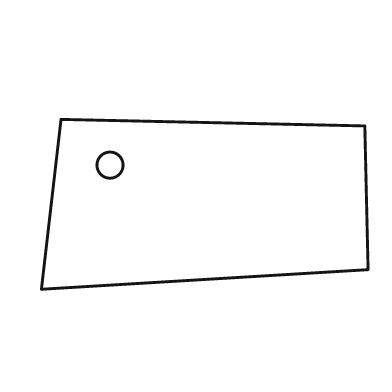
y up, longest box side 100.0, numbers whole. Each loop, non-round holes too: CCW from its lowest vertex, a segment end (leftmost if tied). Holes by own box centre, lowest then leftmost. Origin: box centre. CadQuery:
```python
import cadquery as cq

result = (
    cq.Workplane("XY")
    .moveTo(-50.0, -26.0)
    .lineTo(50.0, -20.0)
    .lineTo(49.0, 24.0)
    .lineTo(-44.0, 26.0)
    .close()
    .moveTo(-29.0, 12.0)
    .circle(4.0)
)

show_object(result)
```